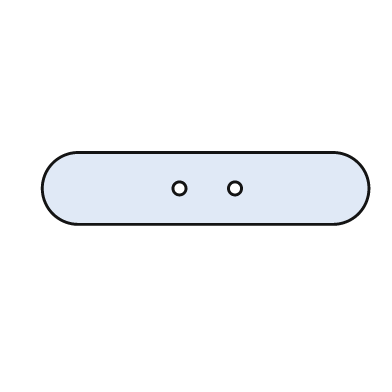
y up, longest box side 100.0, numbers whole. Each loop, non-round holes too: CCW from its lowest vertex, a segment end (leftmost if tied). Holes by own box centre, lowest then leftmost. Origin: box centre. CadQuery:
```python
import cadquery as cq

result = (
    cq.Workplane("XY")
    .moveTo(-39.0, -11.0)
    .lineTo(39.0, -11.0)
    .threePointArc((50.0, 0.0), (39.0, 11.0))
    .lineTo(-39.0, 11.0)
    .threePointArc((-50.0, 0.0), (-39.0, -11.0))
    .close()
    .moveTo(-8.0, 0.0)
    .circle(2.0)
    .moveTo(9.0, 0.0)
    .circle(2.0)
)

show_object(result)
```